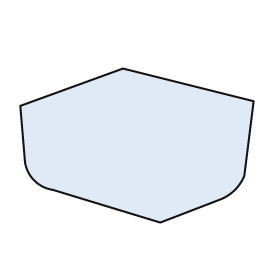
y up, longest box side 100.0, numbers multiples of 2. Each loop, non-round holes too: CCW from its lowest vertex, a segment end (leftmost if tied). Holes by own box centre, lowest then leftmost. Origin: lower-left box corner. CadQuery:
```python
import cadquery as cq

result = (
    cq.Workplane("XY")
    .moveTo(60.0, 0.0)
    .lineTo(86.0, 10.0)
    .threePointArc((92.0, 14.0), (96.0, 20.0))
    .lineTo(100.0, 52.0)
    .lineTo(44.0, 66.0)
    .lineTo(0.0, 50.0)
    .lineTo(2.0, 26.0)
    .threePointArc((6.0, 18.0), (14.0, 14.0))
    .close()
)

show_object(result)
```